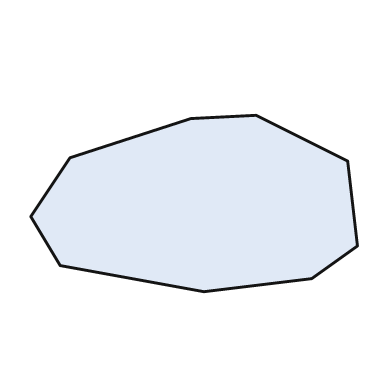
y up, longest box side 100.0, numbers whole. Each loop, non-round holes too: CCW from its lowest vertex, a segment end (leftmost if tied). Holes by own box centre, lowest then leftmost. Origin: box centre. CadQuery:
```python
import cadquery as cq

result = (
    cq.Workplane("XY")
    .moveTo(3.0, -27.0)
    .lineTo(36.0, -23.0)
    .lineTo(50.0, -13.0)
    .lineTo(47.0, 13.0)
    .lineTo(19.0, 27.0)
    .lineTo(-1.0, 26.0)
    .lineTo(-38.0, 14.0)
    .lineTo(-50.0, -4.0)
    .lineTo(-41.0, -19.0)
    .close()
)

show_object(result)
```